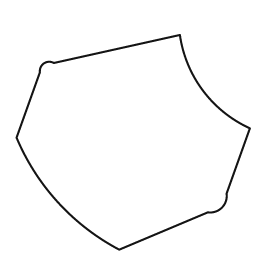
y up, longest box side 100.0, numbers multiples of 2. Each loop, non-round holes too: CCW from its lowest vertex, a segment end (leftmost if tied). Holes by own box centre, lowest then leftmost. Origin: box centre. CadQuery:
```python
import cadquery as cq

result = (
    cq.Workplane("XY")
    .moveTo(-6.0, -46.0)
    .lineTo(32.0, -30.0)
    .threePointArc((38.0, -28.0), (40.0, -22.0))
    .lineTo(50.0, 6.0)
    .threePointArc((30.0, 22.0), (20.0, 46.0))
    .lineTo(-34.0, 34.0)
    .threePointArc((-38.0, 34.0), (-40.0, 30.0))
    .lineTo(-50.0, 2.0)
    .threePointArc((-32.0, -26.0), (-6.0, -46.0))
    .close()
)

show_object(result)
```